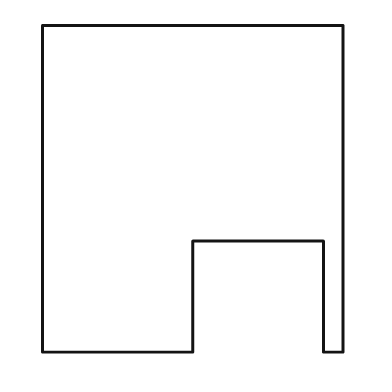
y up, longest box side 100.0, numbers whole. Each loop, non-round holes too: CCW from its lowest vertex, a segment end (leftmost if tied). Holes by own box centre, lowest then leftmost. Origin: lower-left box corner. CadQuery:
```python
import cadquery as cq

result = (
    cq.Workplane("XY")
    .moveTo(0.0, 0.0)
    .lineTo(46.0, 0.0)
    .lineTo(46.0, 34.0)
    .lineTo(86.0, 34.0)
    .lineTo(86.0, 0.0)
    .lineTo(92.0, 0.0)
    .lineTo(92.0, 100.0)
    .lineTo(0.0, 100.0)
    .close()
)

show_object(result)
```